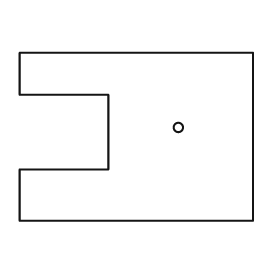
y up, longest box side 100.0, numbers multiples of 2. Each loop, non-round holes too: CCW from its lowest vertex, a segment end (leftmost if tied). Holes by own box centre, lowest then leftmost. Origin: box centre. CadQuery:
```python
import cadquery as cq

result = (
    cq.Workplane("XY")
    .moveTo(-50.0, -36.0)
    .lineTo(50.0, -36.0)
    .lineTo(50.0, 36.0)
    .lineTo(-50.0, 36.0)
    .lineTo(-50.0, 18.0)
    .lineTo(-12.0, 18.0)
    .lineTo(-12.0, -14.0)
    .lineTo(-50.0, -14.0)
    .close()
    .moveTo(18.0, 4.0)
    .circle(2.0)
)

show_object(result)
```